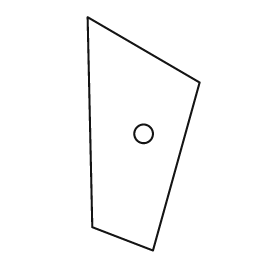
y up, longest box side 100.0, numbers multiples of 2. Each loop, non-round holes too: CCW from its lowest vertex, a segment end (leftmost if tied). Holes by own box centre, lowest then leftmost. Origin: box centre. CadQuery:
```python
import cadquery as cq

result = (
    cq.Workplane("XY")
    .moveTo(4.0, -50.0)
    .lineTo(24.0, 22.0)
    .lineTo(-24.0, 50.0)
    .lineTo(-22.0, -40.0)
    .close()
    .moveTo(0.0, 0.0)
    .circle(4.0)
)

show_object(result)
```